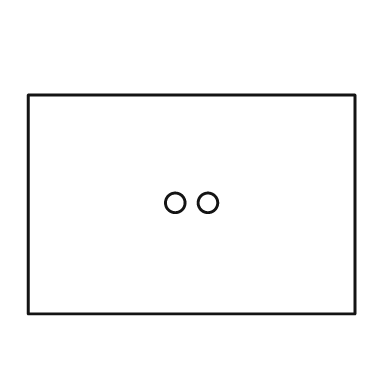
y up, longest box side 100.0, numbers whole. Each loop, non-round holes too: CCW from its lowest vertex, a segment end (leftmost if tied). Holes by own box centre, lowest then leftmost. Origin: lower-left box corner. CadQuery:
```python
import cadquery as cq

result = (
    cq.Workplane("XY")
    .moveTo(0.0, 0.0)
    .lineTo(100.0, 0.0)
    .lineTo(100.0, 67.0)
    .lineTo(0.0, 67.0)
    .close()
    .moveTo(45.0, 34.0)
    .circle(3.0)
    .moveTo(55.0, 34.0)
    .circle(3.0)
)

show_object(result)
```